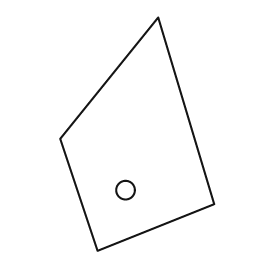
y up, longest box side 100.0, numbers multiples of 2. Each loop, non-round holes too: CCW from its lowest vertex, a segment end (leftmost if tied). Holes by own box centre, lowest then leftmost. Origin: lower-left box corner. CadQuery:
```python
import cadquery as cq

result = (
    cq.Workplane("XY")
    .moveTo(16.0, 0.0)
    .lineTo(66.0, 20.0)
    .lineTo(42.0, 100.0)
    .lineTo(0.0, 48.0)
    .close()
    .moveTo(28.0, 26.0)
    .circle(4.0)
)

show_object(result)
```